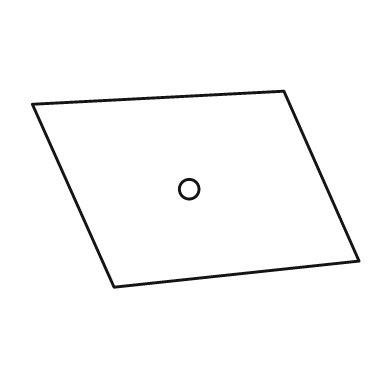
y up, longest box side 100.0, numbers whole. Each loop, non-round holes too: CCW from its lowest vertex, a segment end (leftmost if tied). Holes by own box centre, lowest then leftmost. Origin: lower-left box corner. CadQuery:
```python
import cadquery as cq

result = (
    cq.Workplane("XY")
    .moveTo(25.0, 0.0)
    .lineTo(100.0, 8.0)
    .lineTo(77.0, 60.0)
    .lineTo(0.0, 56.0)
    .close()
    .moveTo(48.0, 30.0)
    .circle(3.0)
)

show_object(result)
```